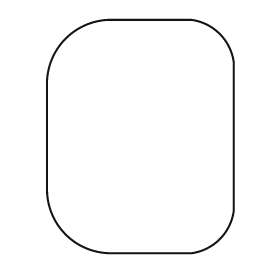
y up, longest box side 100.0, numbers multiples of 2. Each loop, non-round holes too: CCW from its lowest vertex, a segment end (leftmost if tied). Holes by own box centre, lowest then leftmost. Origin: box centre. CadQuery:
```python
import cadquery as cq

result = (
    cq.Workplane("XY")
    .moveTo(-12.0, -50.0)
    .lineTo(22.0, -50.0)
    .threePointArc((34.0, -44.0), (40.0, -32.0))
    .lineTo(40.0, 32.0)
    .threePointArc((34.0, 44.0), (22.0, 50.0))
    .lineTo(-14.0, 50.0)
    .threePointArc((-32.0, 42.0), (-40.0, 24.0))
    .lineTo(-40.0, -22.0)
    .threePointArc((-32.0, -42.0), (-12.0, -50.0))
    .close()
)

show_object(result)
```